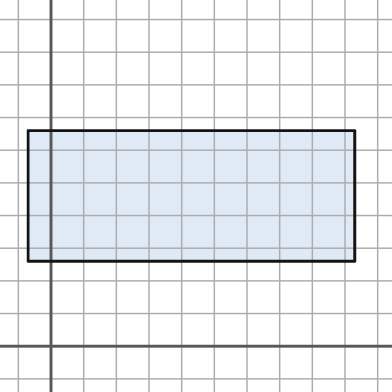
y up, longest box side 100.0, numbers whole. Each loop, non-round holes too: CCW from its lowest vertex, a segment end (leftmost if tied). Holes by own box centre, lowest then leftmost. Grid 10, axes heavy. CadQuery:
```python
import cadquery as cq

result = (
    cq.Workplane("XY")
    .moveTo(-7.0, 26.0)
    .lineTo(93.0, 26.0)
    .lineTo(93.0, 66.0)
    .lineTo(-7.0, 66.0)
    .close()
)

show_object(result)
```